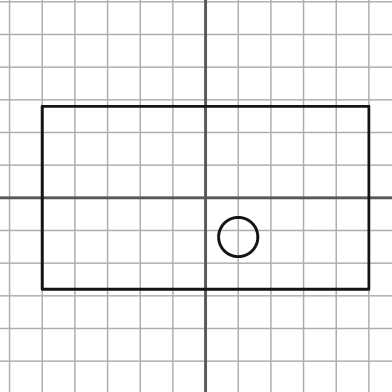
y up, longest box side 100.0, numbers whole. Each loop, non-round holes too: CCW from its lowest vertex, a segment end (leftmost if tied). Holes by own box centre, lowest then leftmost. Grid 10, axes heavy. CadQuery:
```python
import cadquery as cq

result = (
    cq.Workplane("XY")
    .moveTo(-50.0, -28.0)
    .lineTo(50.0, -28.0)
    .lineTo(50.0, 28.0)
    .lineTo(-50.0, 28.0)
    .close()
    .moveTo(10.0, -12.0)
    .circle(6.0)
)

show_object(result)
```